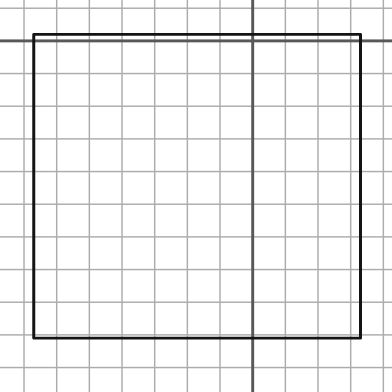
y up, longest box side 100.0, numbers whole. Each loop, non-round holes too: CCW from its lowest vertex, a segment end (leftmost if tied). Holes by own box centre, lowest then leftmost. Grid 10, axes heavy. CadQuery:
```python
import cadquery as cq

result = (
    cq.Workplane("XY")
    .moveTo(-67.0, -91.0)
    .lineTo(33.0, -91.0)
    .lineTo(33.0, 2.0)
    .lineTo(-67.0, 2.0)
    .close()
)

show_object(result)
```